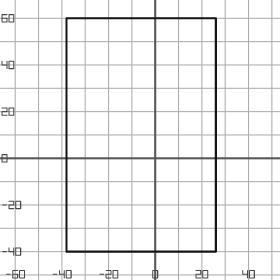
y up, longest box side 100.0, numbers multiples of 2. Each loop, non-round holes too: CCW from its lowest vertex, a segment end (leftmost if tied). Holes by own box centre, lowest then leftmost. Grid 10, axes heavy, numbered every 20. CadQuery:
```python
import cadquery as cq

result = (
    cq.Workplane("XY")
    .moveTo(-38.0, -40.0)
    .lineTo(26.0, -40.0)
    .lineTo(26.0, 60.0)
    .lineTo(-38.0, 60.0)
    .close()
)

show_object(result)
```